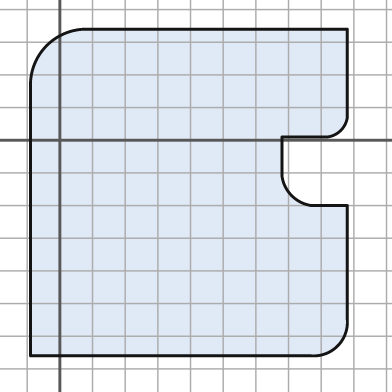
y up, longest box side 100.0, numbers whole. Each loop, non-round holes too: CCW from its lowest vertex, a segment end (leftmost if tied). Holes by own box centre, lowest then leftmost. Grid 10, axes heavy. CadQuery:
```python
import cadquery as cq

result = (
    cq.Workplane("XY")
    .moveTo(-9.0, -66.0)
    .lineTo(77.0, -66.0)
    .threePointArc((85.0, -63.0), (88.0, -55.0))
    .lineTo(88.0, -20.0)
    .lineTo(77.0, -20.0)
    .threePointArc((71.0, -17.0), (68.0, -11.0))
    .lineTo(68.0, 1.0)
    .lineTo(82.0, 1.0)
    .threePointArc((86.0, 3.0), (88.0, 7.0))
    .lineTo(88.0, 34.0)
    .lineTo(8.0, 34.0)
    .threePointArc((-4.0, 29.0), (-9.0, 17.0))
    .close()
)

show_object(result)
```